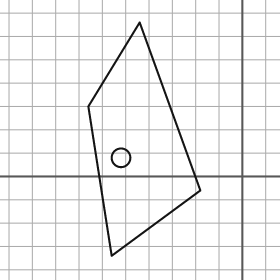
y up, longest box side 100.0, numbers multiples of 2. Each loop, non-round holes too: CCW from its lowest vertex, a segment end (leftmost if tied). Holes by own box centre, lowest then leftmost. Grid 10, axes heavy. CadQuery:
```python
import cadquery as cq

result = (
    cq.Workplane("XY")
    .moveTo(-56.0, -34.0)
    .lineTo(-18.0, -6.0)
    .lineTo(-44.0, 66.0)
    .lineTo(-66.0, 30.0)
    .close()
    .moveTo(-52.0, 8.0)
    .circle(4.0)
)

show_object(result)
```